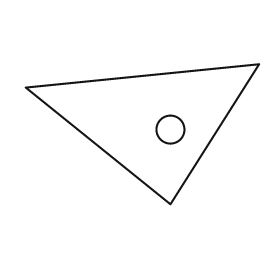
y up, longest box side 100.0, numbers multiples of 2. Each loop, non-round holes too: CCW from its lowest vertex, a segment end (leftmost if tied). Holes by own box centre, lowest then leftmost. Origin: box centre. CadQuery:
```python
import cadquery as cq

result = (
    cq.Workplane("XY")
    .moveTo(12.0, -30.0)
    .lineTo(50.0, 30.0)
    .lineTo(-50.0, 20.0)
    .close()
    .moveTo(12.0, 2.0)
    .circle(6.0)
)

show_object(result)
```